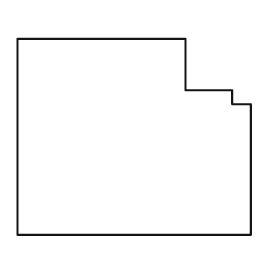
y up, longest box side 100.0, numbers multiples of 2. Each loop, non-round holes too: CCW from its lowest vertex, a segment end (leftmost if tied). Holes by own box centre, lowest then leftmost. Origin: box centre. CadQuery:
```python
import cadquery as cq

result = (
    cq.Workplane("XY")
    .moveTo(-50.0, -42.0)
    .lineTo(50.0, -42.0)
    .lineTo(50.0, 14.0)
    .lineTo(42.0, 14.0)
    .lineTo(42.0, 20.0)
    .lineTo(22.0, 20.0)
    .lineTo(22.0, 42.0)
    .lineTo(-50.0, 42.0)
    .close()
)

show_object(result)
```